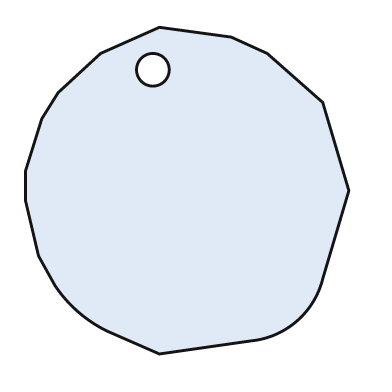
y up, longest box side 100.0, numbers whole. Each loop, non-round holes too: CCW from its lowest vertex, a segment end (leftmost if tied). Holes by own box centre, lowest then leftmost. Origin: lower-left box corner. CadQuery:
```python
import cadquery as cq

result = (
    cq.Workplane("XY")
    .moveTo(41.0, 0.0)
    .lineTo(69.0, 4.0)
    .threePointArc((83.0, 10.0), (91.0, 23.0))
    .lineTo(99.0, 50.0)
    .lineTo(91.0, 77.0)
    .lineTo(74.0, 92.0)
    .lineTo(63.0, 97.0)
    .lineTo(41.0, 100.0)
    .lineTo(23.0, 92.0)
    .lineTo(10.0, 80.0)
    .lineTo(5.0, 72.0)
    .lineTo(0.0, 56.0)
    .lineTo(0.0, 47.0)
    .lineTo(4.0, 30.0)
    .lineTo(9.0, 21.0)
    .threePointArc((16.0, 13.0), (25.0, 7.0))
    .close()
    .moveTo(39.0, 87.0)
    .circle(5.0)
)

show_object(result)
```